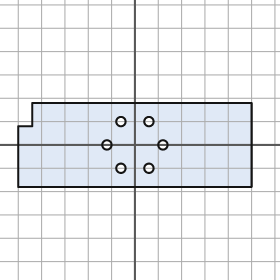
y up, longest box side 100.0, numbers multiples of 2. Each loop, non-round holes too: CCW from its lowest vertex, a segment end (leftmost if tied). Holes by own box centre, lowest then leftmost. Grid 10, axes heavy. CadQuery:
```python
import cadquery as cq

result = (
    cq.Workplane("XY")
    .moveTo(-50.0, -18.0)
    .lineTo(50.0, -18.0)
    .lineTo(50.0, 18.0)
    .lineTo(-44.0, 18.0)
    .lineTo(-44.0, 8.0)
    .lineTo(-50.0, 8.0)
    .close()
    .moveTo(-6.0, -10.0)
    .circle(2.0)
    .moveTo(6.0, -10.0)
    .circle(2.0)
    .moveTo(-12.0, 0.0)
    .circle(2.0)
    .moveTo(12.0, 0.0)
    .circle(2.0)
    .moveTo(-6.0, 10.0)
    .circle(2.0)
    .moveTo(6.0, 10.0)
    .circle(2.0)
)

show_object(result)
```